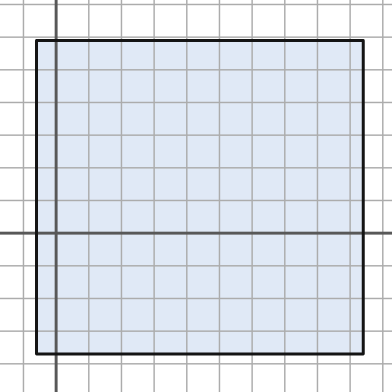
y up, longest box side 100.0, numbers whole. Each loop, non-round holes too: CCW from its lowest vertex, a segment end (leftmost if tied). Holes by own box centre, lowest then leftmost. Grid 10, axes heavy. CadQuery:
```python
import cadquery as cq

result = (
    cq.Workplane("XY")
    .moveTo(-6.0, -37.0)
    .lineTo(94.0, -37.0)
    .lineTo(94.0, 59.0)
    .lineTo(-6.0, 59.0)
    .close()
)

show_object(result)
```